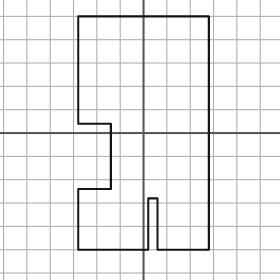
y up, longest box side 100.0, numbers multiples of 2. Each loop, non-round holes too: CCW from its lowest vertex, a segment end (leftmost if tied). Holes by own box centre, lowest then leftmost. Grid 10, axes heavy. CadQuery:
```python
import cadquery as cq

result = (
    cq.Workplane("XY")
    .moveTo(-28.0, -50.0)
    .lineTo(2.0, -50.0)
    .lineTo(2.0, -28.0)
    .lineTo(6.0, -28.0)
    .lineTo(6.0, -50.0)
    .lineTo(28.0, -50.0)
    .lineTo(28.0, 50.0)
    .lineTo(-28.0, 50.0)
    .lineTo(-28.0, 4.0)
    .lineTo(-14.0, 4.0)
    .lineTo(-14.0, -24.0)
    .lineTo(-28.0, -24.0)
    .close()
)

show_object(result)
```